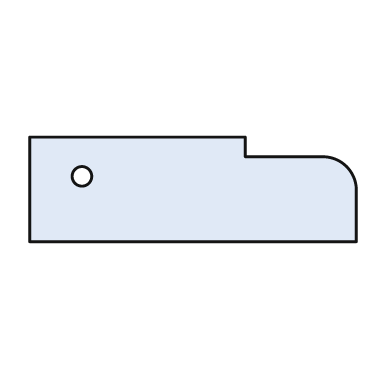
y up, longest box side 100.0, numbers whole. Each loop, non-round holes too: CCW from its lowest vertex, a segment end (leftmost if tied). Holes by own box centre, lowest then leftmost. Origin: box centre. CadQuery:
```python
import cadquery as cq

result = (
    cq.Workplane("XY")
    .moveTo(-50.0, -16.0)
    .lineTo(50.0, -16.0)
    .lineTo(50.0, 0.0)
    .threePointArc((47.0, 7.0), (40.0, 10.0))
    .lineTo(16.0, 10.0)
    .lineTo(16.0, 16.0)
    .lineTo(-50.0, 16.0)
    .close()
    .moveTo(-34.0, 4.0)
    .circle(3.0)
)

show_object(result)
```